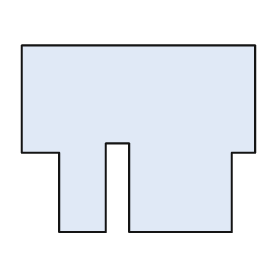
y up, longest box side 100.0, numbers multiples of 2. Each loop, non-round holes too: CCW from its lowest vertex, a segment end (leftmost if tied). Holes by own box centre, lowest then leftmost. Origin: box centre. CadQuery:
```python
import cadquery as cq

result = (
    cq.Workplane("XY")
    .moveTo(-34.0, -40.0)
    .lineTo(-14.0, -40.0)
    .lineTo(-14.0, -2.0)
    .lineTo(-4.0, -2.0)
    .lineTo(-4.0, -40.0)
    .lineTo(40.0, -40.0)
    .lineTo(40.0, -6.0)
    .lineTo(50.0, -6.0)
    .lineTo(50.0, 40.0)
    .lineTo(-50.0, 40.0)
    .lineTo(-50.0, -6.0)
    .lineTo(-34.0, -6.0)
    .close()
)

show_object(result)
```